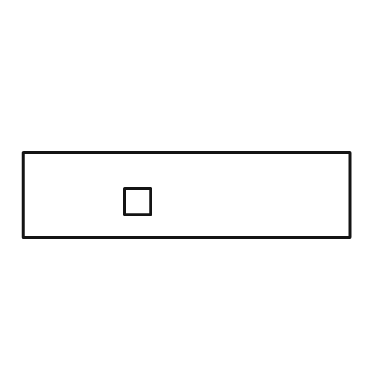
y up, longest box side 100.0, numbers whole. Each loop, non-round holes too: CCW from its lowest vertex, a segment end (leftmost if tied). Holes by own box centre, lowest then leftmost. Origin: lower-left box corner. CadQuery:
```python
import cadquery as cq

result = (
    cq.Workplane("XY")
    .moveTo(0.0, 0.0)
    .lineTo(100.0, 0.0)
    .lineTo(100.0, 26.0)
    .lineTo(0.0, 26.0)
    .close()
    .moveTo(31.0, 7.0)
    .lineTo(39.0, 7.0)
    .lineTo(39.0, 15.0)
    .lineTo(31.0, 15.0)
    .close()
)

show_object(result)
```